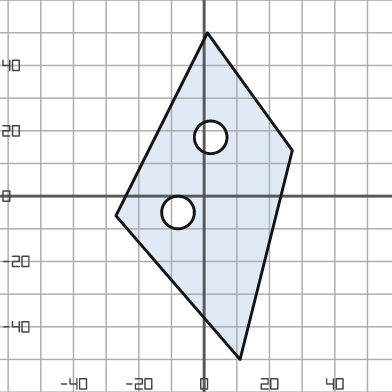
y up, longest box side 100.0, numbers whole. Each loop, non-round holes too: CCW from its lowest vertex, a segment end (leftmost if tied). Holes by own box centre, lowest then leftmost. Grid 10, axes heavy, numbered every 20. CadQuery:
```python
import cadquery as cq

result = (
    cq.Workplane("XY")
    .moveTo(11.0, -50.0)
    .lineTo(27.0, 14.0)
    .lineTo(1.0, 50.0)
    .lineTo(-27.0, -6.0)
    .close()
    .moveTo(-8.0, -5.0)
    .circle(5.0)
    .moveTo(2.0, 18.0)
    .circle(5.0)
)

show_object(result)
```